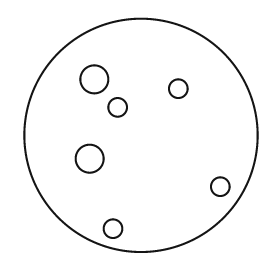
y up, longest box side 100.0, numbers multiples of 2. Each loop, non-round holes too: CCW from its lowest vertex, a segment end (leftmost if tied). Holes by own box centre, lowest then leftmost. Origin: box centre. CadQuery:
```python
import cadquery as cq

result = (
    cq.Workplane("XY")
    .moveTo(0.0, 0.0)
    .circle(50.0)
    .moveTo(-12.0, -40.0)
    .circle(4.0)
    .moveTo(34.0, -22.0)
    .circle(4.0)
    .moveTo(-22.0, -10.0)
    .circle(6.0)
    .moveTo(-10.0, 12.0)
    .circle(4.0)
    .moveTo(16.0, 20.0)
    .circle(4.0)
    .moveTo(-20.0, 24.0)
    .circle(6.0)
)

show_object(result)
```